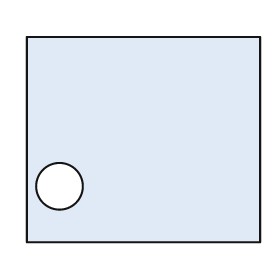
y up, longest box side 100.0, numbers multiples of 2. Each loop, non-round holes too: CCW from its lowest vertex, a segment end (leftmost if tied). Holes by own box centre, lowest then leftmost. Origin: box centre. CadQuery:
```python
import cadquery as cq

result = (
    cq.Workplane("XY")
    .moveTo(-50.0, -44.0)
    .lineTo(50.0, -44.0)
    .lineTo(50.0, 44.0)
    .lineTo(-50.0, 44.0)
    .close()
    .moveTo(-36.0, -20.0)
    .circle(10.0)
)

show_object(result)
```